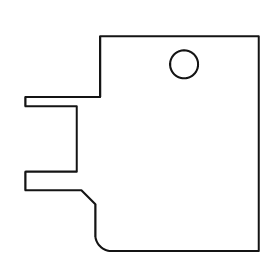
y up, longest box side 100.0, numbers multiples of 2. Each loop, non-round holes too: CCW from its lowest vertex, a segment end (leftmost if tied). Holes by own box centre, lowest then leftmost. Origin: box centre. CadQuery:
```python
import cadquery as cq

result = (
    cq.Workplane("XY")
    .moveTo(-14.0, -46.0)
    .lineTo(50.0, -46.0)
    .lineTo(50.0, 46.0)
    .lineTo(-18.0, 46.0)
    .lineTo(-18.0, 20.0)
    .lineTo(-50.0, 20.0)
    .lineTo(-50.0, 16.0)
    .lineTo(-28.0, 16.0)
    .lineTo(-28.0, -12.0)
    .lineTo(-50.0, -12.0)
    .lineTo(-50.0, -20.0)
    .lineTo(-26.0, -20.0)
    .lineTo(-20.0, -26.0)
    .lineTo(-20.0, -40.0)
    .threePointArc((-18.0, -44.0), (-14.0, -46.0))
    .close()
    .moveTo(18.0, 34.0)
    .circle(6.0)
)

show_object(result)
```